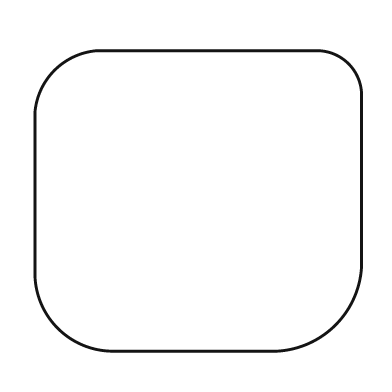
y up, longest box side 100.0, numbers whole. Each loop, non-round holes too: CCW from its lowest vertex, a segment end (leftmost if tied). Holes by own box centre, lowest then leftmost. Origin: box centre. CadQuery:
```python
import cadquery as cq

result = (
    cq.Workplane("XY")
    .moveTo(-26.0, -46.0)
    .lineTo(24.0, -46.0)
    .threePointArc((42.0, -38.0), (50.0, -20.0))
    .lineTo(50.0, 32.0)
    .threePointArc((46.0, 42.0), (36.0, 46.0))
    .lineTo(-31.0, 46.0)
    .threePointArc((-44.0, 40.0), (-50.0, 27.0))
    .lineTo(-50.0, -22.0)
    .threePointArc((-43.0, -39.0), (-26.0, -46.0))
    .close()
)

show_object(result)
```